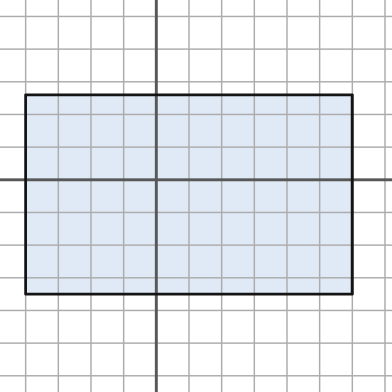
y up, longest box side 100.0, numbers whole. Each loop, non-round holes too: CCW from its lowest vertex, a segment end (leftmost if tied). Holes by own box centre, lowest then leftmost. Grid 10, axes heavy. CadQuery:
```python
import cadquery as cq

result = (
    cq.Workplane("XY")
    .moveTo(-40.0, -35.0)
    .lineTo(60.0, -35.0)
    .lineTo(60.0, 26.0)
    .lineTo(-40.0, 26.0)
    .close()
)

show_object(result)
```